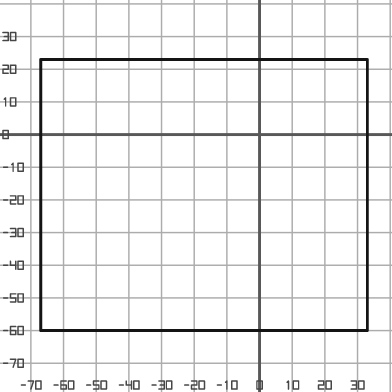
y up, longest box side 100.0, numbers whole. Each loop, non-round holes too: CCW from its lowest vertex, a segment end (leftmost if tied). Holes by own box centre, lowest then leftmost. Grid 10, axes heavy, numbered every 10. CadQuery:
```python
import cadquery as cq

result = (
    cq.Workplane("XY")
    .moveTo(-67.0, -60.0)
    .lineTo(33.0, -60.0)
    .lineTo(33.0, 23.0)
    .lineTo(-67.0, 23.0)
    .close()
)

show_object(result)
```